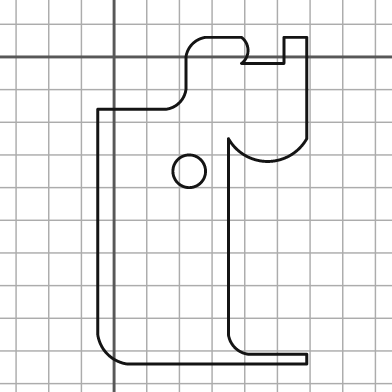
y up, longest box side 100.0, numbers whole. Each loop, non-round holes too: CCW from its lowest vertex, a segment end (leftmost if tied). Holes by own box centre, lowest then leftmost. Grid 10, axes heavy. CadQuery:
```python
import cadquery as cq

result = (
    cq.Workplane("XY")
    .moveTo(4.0, -94.0)
    .lineTo(59.0, -94.0)
    .lineTo(59.0, -91.0)
    .lineTo(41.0, -91.0)
    .threePointArc((37.0, -89.0), (35.0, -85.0))
    .lineTo(35.0, -25.0)
    .threePointArc((47.0, -32.0), (59.0, -25.0))
    .lineTo(59.0, 6.0)
    .lineTo(52.0, 6.0)
    .lineTo(52.0, -2.0)
    .lineTo(39.0, -2.0)
    .threePointArc((41.0, 2.0), (39.0, 6.0))
    .lineTo(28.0, 6.0)
    .threePointArc((24.0, 4.0), (22.0, 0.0))
    .lineTo(22.0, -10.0)
    .threePointArc((20.0, -14.0), (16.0, -16.0))
    .lineTo(-5.0, -16.0)
    .lineTo(-5.0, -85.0)
    .threePointArc((-2.0, -91.0), (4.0, -94.0))
    .close()
    .moveTo(23.0, -35.0)
    .circle(5.0)
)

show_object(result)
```